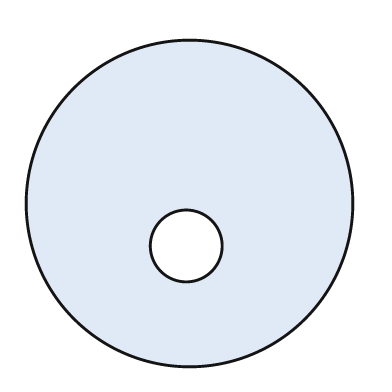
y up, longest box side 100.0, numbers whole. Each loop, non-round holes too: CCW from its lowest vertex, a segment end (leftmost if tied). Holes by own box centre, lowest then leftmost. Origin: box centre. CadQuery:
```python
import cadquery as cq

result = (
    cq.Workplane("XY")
    .moveTo(0.0, 0.0)
    .circle(50.0)
    .moveTo(-1.0, -13.0)
    .circle(11.0)
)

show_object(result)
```